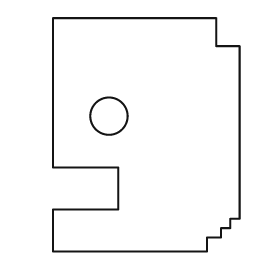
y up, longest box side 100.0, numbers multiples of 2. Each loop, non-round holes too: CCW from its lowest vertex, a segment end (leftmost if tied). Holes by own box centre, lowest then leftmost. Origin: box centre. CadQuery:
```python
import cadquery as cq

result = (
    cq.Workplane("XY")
    .moveTo(-40.0, -50.0)
    .lineTo(26.0, -50.0)
    .lineTo(26.0, -44.0)
    .lineTo(32.0, -44.0)
    .lineTo(32.0, -40.0)
    .lineTo(36.0, -40.0)
    .lineTo(36.0, -36.0)
    .lineTo(40.0, -36.0)
    .lineTo(40.0, 38.0)
    .lineTo(30.0, 38.0)
    .lineTo(30.0, 50.0)
    .lineTo(-40.0, 50.0)
    .lineTo(-40.0, -14.0)
    .lineTo(-12.0, -14.0)
    .lineTo(-12.0, -32.0)
    .lineTo(-40.0, -32.0)
    .close()
    .moveTo(-16.0, 8.0)
    .circle(8.0)
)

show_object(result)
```